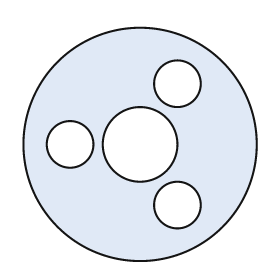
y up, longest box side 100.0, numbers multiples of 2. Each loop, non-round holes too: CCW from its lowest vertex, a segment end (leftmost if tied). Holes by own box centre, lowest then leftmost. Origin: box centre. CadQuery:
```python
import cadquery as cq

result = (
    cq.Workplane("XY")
    .moveTo(0.0, 0.0)
    .circle(50.0)
    .moveTo(16.0, -26.0)
    .circle(10.0)
    .moveTo(-30.0, 0.0)
    .circle(10.0)
    .moveTo(0.0, 0.0)
    .circle(16.0)
    .moveTo(16.0, 26.0)
    .circle(10.0)
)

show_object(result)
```